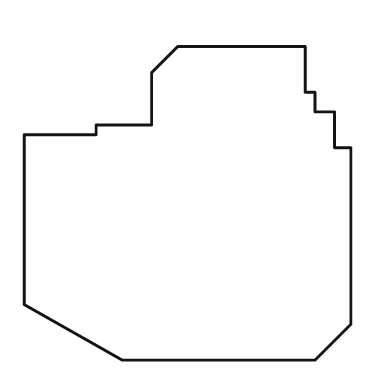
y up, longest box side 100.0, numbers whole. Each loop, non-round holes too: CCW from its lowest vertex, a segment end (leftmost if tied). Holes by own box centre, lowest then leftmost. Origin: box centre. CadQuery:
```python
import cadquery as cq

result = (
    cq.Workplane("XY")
    .moveTo(-20.0, -48.0)
    .lineTo(39.0, -48.0)
    .lineTo(50.0, -37.0)
    .lineTo(50.0, 17.0)
    .lineTo(45.0, 17.0)
    .lineTo(45.0, 28.0)
    .lineTo(39.0, 28.0)
    .lineTo(39.0, 34.0)
    .lineTo(36.0, 34.0)
    .lineTo(36.0, 48.0)
    .lineTo(-3.0, 48.0)
    .lineTo(-11.0, 40.0)
    .lineTo(-11.0, 24.0)
    .lineTo(-28.0, 24.0)
    .lineTo(-28.0, 21.0)
    .lineTo(-50.0, 21.0)
    .lineTo(-50.0, -31.0)
    .close()
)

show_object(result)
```